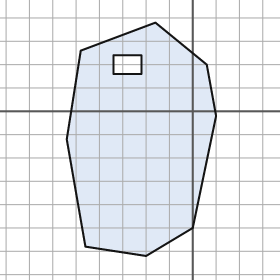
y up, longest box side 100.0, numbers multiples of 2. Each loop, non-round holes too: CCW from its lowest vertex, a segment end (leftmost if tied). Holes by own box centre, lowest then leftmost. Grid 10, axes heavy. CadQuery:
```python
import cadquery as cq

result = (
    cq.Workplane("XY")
    .moveTo(-20.0, -62.0)
    .lineTo(0.0, -50.0)
    .lineTo(10.0, -2.0)
    .lineTo(6.0, 20.0)
    .lineTo(-16.0, 38.0)
    .lineTo(-48.0, 26.0)
    .lineTo(-54.0, -12.0)
    .lineTo(-46.0, -58.0)
    .close()
    .moveTo(-34.0, 16.0)
    .lineTo(-22.0, 16.0)
    .lineTo(-22.0, 24.0)
    .lineTo(-34.0, 24.0)
    .close()
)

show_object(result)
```